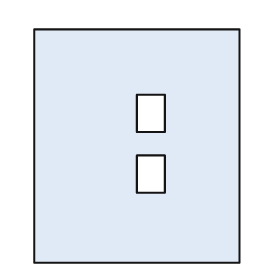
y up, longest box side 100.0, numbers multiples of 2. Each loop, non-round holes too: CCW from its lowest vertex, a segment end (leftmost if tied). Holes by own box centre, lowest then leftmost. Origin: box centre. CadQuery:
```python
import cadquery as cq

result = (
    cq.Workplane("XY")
    .moveTo(-44.0, -50.0)
    .lineTo(44.0, -50.0)
    .lineTo(44.0, 50.0)
    .lineTo(-44.0, 50.0)
    .close()
    .moveTo(0.0, -20.0)
    .lineTo(12.0, -20.0)
    .lineTo(12.0, -4.0)
    .lineTo(0.0, -4.0)
    .close()
    .moveTo(0.0, 6.0)
    .lineTo(12.0, 6.0)
    .lineTo(12.0, 22.0)
    .lineTo(0.0, 22.0)
    .close()
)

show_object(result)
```